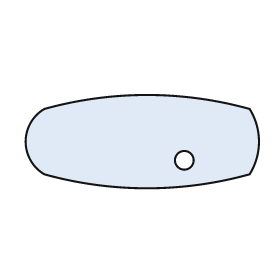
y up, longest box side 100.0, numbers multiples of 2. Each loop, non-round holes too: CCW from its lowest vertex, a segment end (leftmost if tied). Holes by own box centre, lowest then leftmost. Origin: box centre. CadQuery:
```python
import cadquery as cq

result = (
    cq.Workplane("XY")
    .moveTo(-42.0, -14.0)
    .threePointArc((2.0, -20.0), (46.0, -14.0))
    .threePointArc((50.0, 0.0), (46.0, 14.0))
    .threePointArc((2.0, 20.0), (-42.0, 14.0))
    .threePointArc((-50.0, 0.0), (-42.0, -14.0))
    .close()
    .moveTo(18.0, -8.0)
    .circle(4.0)
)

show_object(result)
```